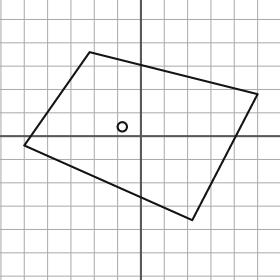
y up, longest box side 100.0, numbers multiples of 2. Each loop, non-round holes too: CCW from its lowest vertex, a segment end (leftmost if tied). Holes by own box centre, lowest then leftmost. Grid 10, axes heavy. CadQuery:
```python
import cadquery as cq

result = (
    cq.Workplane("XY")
    .moveTo(22.0, -36.0)
    .lineTo(50.0, 18.0)
    .lineTo(-22.0, 36.0)
    .lineTo(-50.0, -4.0)
    .close()
    .moveTo(-8.0, 4.0)
    .circle(2.0)
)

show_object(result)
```